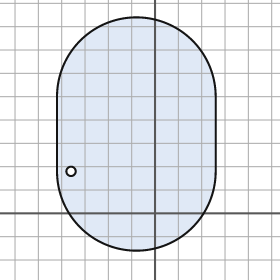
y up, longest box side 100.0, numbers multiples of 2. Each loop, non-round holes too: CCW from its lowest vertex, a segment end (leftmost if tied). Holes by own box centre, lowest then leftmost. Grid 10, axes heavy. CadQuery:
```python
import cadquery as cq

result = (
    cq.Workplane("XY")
    .moveTo(-42.0, 18.0)
    .threePointArc((-8.0, -16.0), (26.0, 18.0))
    .lineTo(26.0, 50.0)
    .threePointArc((-8.0, 84.0), (-42.0, 50.0))
    .close()
    .moveTo(-36.0, 18.0)
    .circle(2.0)
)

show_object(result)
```